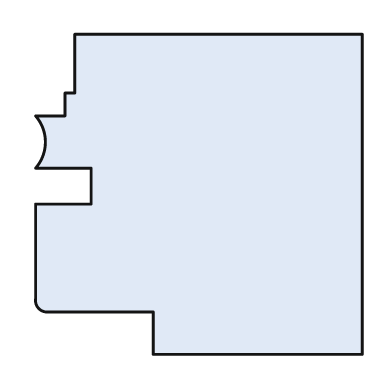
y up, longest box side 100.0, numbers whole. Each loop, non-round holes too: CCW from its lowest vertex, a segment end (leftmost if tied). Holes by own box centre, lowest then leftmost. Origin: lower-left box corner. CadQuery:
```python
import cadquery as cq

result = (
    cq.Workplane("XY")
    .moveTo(36.0, 0.0)
    .lineTo(100.0, 0.0)
    .lineTo(100.0, 98.0)
    .lineTo(12.0, 98.0)
    .lineTo(12.0, 80.0)
    .lineTo(9.0, 80.0)
    .lineTo(9.0, 73.0)
    .lineTo(0.0, 73.0)
    .threePointArc((3.0, 65.0), (0.0, 57.0))
    .lineTo(17.0, 57.0)
    .lineTo(17.0, 46.0)
    .lineTo(0.0, 46.0)
    .lineTo(0.0, 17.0)
    .threePointArc((1.0, 14.0), (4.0, 13.0))
    .lineTo(36.0, 13.0)
    .close()
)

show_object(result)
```